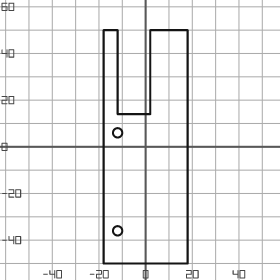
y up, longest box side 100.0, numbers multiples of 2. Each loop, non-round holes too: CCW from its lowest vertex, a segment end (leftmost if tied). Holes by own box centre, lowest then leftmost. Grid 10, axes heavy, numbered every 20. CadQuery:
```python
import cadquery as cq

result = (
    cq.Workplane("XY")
    .moveTo(-18.0, -50.0)
    .lineTo(18.0, -50.0)
    .lineTo(18.0, 50.0)
    .lineTo(2.0, 50.0)
    .lineTo(2.0, 14.0)
    .lineTo(-12.0, 14.0)
    .lineTo(-12.0, 50.0)
    .lineTo(-18.0, 50.0)
    .close()
    .moveTo(-12.0, -36.0)
    .circle(2.0)
    .moveTo(-12.0, 6.0)
    .circle(2.0)
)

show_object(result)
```